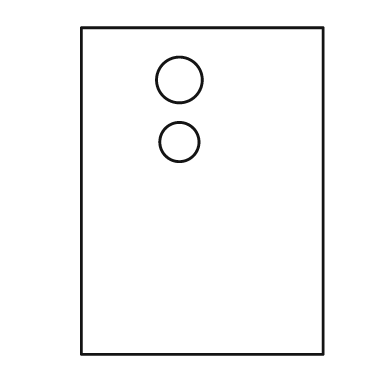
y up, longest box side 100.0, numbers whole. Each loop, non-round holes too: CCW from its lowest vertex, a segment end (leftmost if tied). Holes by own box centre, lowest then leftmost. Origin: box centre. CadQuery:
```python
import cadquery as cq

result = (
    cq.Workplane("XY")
    .moveTo(-37.0, -50.0)
    .lineTo(37.0, -50.0)
    .lineTo(37.0, 50.0)
    .lineTo(-37.0, 50.0)
    .close()
    .moveTo(-7.0, 15.0)
    .circle(6.0)
    .moveTo(-7.0, 34.0)
    .circle(7.0)
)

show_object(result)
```